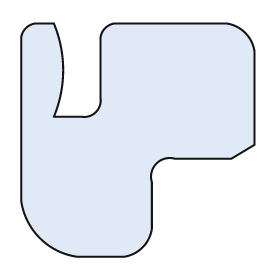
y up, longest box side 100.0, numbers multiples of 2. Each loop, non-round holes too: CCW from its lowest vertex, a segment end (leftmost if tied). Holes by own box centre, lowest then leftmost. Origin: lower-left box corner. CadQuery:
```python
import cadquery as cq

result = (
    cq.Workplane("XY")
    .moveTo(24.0, 0.0)
    .lineTo(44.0, 0.0)
    .threePointArc((52.0, 4.0), (56.0, 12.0))
    .lineTo(56.0, 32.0)
    .threePointArc((58.0, 40.0), (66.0, 42.0))
    .lineTo(90.0, 42.0)
    .lineTo(100.0, 48.0)
    .lineTo(100.0, 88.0)
    .threePointArc((96.0, 96.0), (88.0, 100.0))
    .lineTo(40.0, 100.0)
    .threePointArc((36.0, 98.0), (34.0, 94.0))
    .lineTo(34.0, 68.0)
    .threePointArc((32.0, 62.0), (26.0, 60.0))
    .lineTo(14.0, 60.0)
    .threePointArc((18.0, 80.0), (14.0, 100.0))
    .lineTo(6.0, 100.0)
    .threePointArc((2.0, 98.0), (0.0, 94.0))
    .lineTo(0.0, 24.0)
    .threePointArc((8.0, 8.0), (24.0, 0.0))
    .close()
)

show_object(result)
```